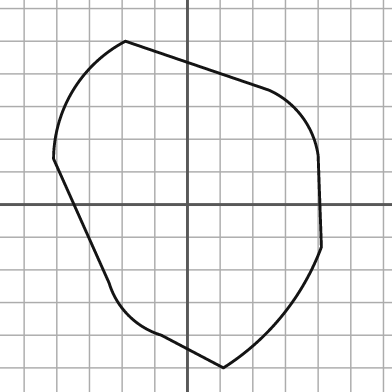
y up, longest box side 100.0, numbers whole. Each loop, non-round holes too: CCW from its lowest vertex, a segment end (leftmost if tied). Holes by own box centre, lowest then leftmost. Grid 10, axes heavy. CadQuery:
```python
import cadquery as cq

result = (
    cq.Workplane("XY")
    .moveTo(11.0, -50.0)
    .threePointArc((29.0, -34.0), (41.0, -13.0))
    .lineTo(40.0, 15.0)
    .threePointArc((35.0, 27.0), (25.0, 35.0))
    .lineTo(-19.0, 50.0)
    .threePointArc((-35.0, 35.0), (-41.0, 14.0))
    .lineTo(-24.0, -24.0)
    .threePointArc((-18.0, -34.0), (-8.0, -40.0))
    .close()
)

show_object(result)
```